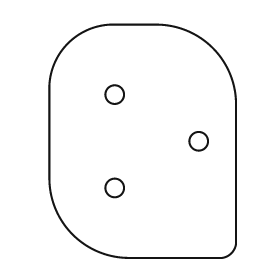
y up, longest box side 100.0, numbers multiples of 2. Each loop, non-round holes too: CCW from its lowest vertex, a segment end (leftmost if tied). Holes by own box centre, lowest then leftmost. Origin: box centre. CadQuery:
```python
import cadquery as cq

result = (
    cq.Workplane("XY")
    .moveTo(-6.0, -50.0)
    .lineTo(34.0, -50.0)
    .threePointArc((38.0, -48.0), (40.0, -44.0))
    .lineTo(40.0, 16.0)
    .threePointArc((30.0, 40.0), (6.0, 50.0))
    .lineTo(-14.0, 50.0)
    .threePointArc((-32.0, 42.0), (-40.0, 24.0))
    .lineTo(-40.0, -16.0)
    .threePointArc((-30.0, -40.0), (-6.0, -50.0))
    .close()
    .moveTo(-12.0, -20.0)
    .circle(4.0)
    .moveTo(24.0, 0.0)
    .circle(4.0)
    .moveTo(-12.0, 20.0)
    .circle(4.0)
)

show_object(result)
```